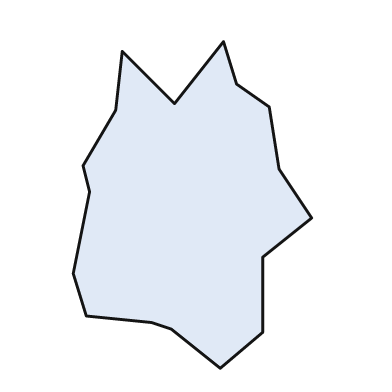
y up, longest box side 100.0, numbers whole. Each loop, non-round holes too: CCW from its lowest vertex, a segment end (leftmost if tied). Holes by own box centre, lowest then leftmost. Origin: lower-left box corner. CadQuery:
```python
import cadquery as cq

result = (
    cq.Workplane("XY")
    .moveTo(45.0, 0.0)
    .lineTo(58.0, 11.0)
    .lineTo(58.0, 34.0)
    .lineTo(73.0, 46.0)
    .lineTo(63.0, 61.0)
    .lineTo(60.0, 80.0)
    .lineTo(50.0, 87.0)
    .lineTo(46.0, 100.0)
    .lineTo(31.0, 81.0)
    .lineTo(15.0, 97.0)
    .lineTo(13.0, 79.0)
    .lineTo(3.0, 62.0)
    .lineTo(5.0, 54.0)
    .lineTo(0.0, 29.0)
    .lineTo(4.0, 16.0)
    .lineTo(24.0, 14.0)
    .lineTo(30.0, 12.0)
    .close()
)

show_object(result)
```